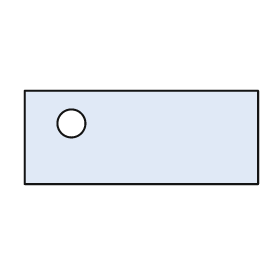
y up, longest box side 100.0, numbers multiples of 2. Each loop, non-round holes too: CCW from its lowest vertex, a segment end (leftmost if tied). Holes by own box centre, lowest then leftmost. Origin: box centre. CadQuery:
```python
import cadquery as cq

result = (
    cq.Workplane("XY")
    .moveTo(-50.0, -20.0)
    .lineTo(50.0, -20.0)
    .lineTo(50.0, 20.0)
    .lineTo(-50.0, 20.0)
    .close()
    .moveTo(-30.0, 6.0)
    .circle(6.0)
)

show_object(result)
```